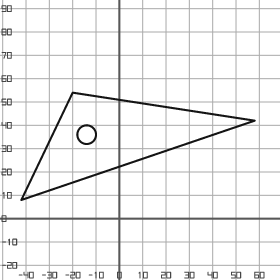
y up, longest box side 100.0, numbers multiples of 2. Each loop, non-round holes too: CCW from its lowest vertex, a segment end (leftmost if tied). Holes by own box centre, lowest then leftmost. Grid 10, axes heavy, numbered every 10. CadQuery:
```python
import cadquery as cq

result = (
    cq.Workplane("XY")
    .moveTo(-42.0, 8.0)
    .lineTo(58.0, 42.0)
    .lineTo(-20.0, 54.0)
    .close()
    .moveTo(-14.0, 36.0)
    .circle(4.0)
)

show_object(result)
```